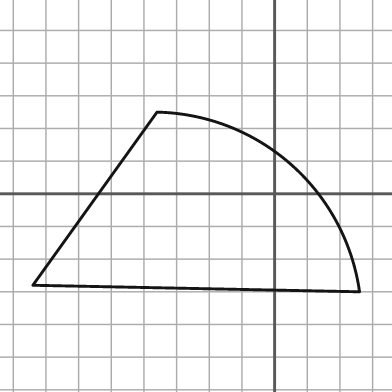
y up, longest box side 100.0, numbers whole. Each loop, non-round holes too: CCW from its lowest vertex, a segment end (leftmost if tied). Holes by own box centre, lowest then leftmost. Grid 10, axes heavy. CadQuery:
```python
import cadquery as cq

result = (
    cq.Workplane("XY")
    .moveTo(26.0, -30.0)
    .threePointArc((5.0, 9.0), (-36.0, 25.0))
    .lineTo(-74.0, -28.0)
    .close()
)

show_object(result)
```